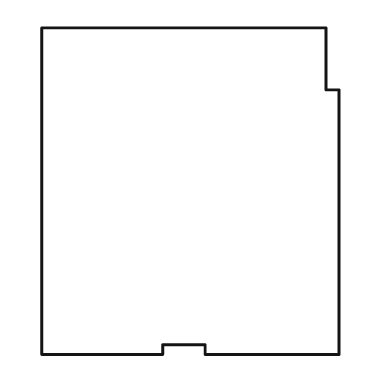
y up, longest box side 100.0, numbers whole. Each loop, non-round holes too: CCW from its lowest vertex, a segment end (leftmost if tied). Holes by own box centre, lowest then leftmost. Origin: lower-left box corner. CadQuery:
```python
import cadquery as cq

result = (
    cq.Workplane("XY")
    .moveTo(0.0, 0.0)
    .lineTo(37.0, 0.0)
    .lineTo(37.0, 3.0)
    .lineTo(50.0, 3.0)
    .lineTo(50.0, 0.0)
    .lineTo(91.0, 0.0)
    .lineTo(91.0, 81.0)
    .lineTo(87.0, 81.0)
    .lineTo(87.0, 100.0)
    .lineTo(0.0, 100.0)
    .close()
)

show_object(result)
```